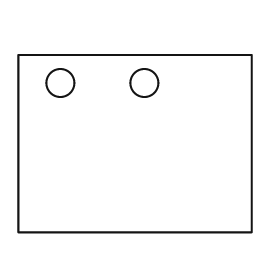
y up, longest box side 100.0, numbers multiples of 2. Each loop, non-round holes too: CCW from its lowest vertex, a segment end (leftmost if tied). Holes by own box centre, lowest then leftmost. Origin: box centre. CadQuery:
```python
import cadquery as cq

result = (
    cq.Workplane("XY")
    .moveTo(-50.0, -38.0)
    .lineTo(50.0, -38.0)
    .lineTo(50.0, 38.0)
    .lineTo(-50.0, 38.0)
    .close()
    .moveTo(-32.0, 26.0)
    .circle(6.0)
    .moveTo(4.0, 26.0)
    .circle(6.0)
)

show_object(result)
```